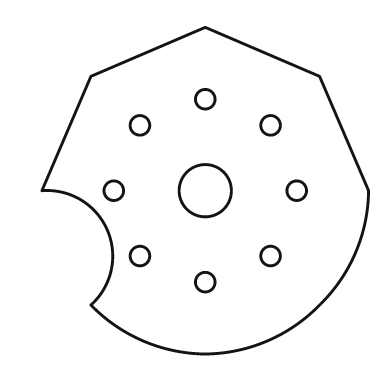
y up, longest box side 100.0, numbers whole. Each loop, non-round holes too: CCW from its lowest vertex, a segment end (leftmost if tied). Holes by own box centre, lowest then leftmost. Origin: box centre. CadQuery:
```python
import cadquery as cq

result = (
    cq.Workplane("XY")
    .moveTo(0.0, -50.0)
    .threePointArc((19.0, -46.0), (35.0, -35.0))
    .threePointArc((46.0, -19.0), (50.0, 0.0))
    .lineTo(35.0, 35.0)
    .lineTo(0.0, 50.0)
    .lineTo(-35.0, 35.0)
    .lineTo(-50.0, 0.0)
    .threePointArc((-30.0, -12.0), (-35.0, -35.0))
    .threePointArc((-19.0, -46.0), (0.0, -50.0))
    .close()
    .moveTo(0.0, -28.0)
    .circle(3.0)
    .moveTo(-20.0, -20.0)
    .circle(3.0)
    .moveTo(20.0, -20.0)
    .circle(3.0)
    .moveTo(-28.0, 0.0)
    .circle(3.0)
    .moveTo(0.0, 0.0)
    .circle(8.0)
    .moveTo(28.0, 0.0)
    .circle(3.0)
    .moveTo(-20.0, 20.0)
    .circle(3.0)
    .moveTo(20.0, 20.0)
    .circle(3.0)
    .moveTo(0.0, 28.0)
    .circle(3.0)
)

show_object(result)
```